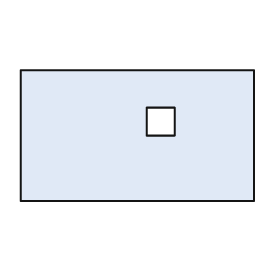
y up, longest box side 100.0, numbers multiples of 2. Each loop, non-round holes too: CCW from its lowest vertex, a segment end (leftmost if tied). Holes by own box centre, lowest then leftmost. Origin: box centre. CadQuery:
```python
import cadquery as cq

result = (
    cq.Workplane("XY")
    .moveTo(-50.0, -28.0)
    .lineTo(50.0, -28.0)
    .lineTo(50.0, 28.0)
    .lineTo(-50.0, 28.0)
    .close()
    .moveTo(4.0, 0.0)
    .lineTo(16.0, 0.0)
    .lineTo(16.0, 12.0)
    .lineTo(4.0, 12.0)
    .close()
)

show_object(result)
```